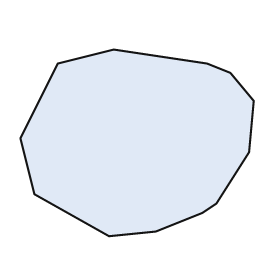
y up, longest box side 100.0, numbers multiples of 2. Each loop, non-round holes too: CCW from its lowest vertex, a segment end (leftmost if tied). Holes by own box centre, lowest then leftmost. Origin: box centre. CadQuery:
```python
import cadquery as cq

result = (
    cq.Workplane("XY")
    .moveTo(-12.0, -40.0)
    .lineTo(8.0, -38.0)
    .lineTo(28.0, -30.0)
    .lineTo(34.0, -26.0)
    .lineTo(48.0, -4.0)
    .lineTo(50.0, 18.0)
    .lineTo(40.0, 30.0)
    .lineTo(30.0, 34.0)
    .lineTo(-10.0, 40.0)
    .lineTo(-34.0, 34.0)
    .lineTo(-50.0, 2.0)
    .lineTo(-44.0, -22.0)
    .close()
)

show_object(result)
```